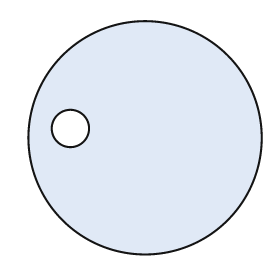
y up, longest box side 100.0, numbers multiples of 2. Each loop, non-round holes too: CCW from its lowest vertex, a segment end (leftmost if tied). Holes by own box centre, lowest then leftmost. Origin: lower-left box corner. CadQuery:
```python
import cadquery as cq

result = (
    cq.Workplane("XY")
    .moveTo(50.0, 50.0)
    .circle(50.0)
    .moveTo(18.0, 54.0)
    .circle(8.0)
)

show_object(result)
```